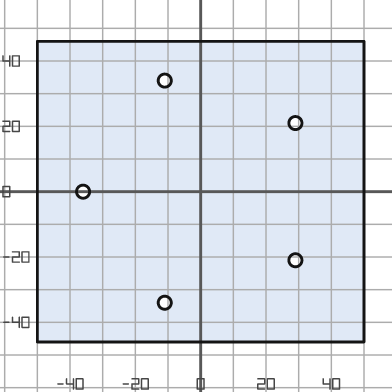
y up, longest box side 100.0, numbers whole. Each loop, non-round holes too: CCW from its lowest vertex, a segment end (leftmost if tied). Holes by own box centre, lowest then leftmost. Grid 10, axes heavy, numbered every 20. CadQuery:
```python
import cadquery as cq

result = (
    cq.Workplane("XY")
    .moveTo(-50.0, -46.0)
    .lineTo(50.0, -46.0)
    .lineTo(50.0, 46.0)
    .lineTo(-50.0, 46.0)
    .close()
    .moveTo(-11.0, -34.0)
    .circle(2.0)
    .moveTo(29.0, -21.0)
    .circle(2.0)
    .moveTo(-36.0, 0.0)
    .circle(2.0)
    .moveTo(29.0, 21.0)
    .circle(2.0)
    .moveTo(-11.0, 34.0)
    .circle(2.0)
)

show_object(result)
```